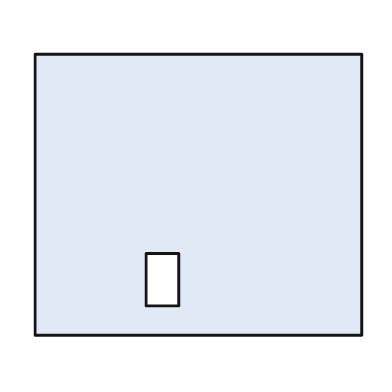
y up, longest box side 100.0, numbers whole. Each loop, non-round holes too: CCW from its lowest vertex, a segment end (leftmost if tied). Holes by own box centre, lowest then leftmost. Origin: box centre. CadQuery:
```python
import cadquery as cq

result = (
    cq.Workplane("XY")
    .moveTo(-50.0, -43.0)
    .lineTo(50.0, -43.0)
    .lineTo(50.0, 43.0)
    .lineTo(-50.0, 43.0)
    .close()
    .moveTo(-16.0, -34.0)
    .lineTo(-6.0, -34.0)
    .lineTo(-6.0, -18.0)
    .lineTo(-16.0, -18.0)
    .close()
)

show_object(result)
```